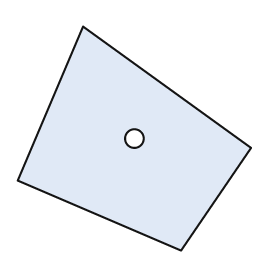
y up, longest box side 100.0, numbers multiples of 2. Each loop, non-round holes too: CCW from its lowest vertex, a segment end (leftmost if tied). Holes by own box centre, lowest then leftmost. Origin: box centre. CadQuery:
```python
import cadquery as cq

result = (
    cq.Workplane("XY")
    .moveTo(20.0, -48.0)
    .lineTo(50.0, -4.0)
    .lineTo(-22.0, 48.0)
    .lineTo(-50.0, -18.0)
    .close()
    .moveTo(0.0, 0.0)
    .circle(4.0)
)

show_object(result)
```